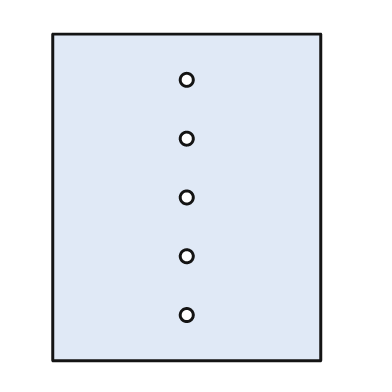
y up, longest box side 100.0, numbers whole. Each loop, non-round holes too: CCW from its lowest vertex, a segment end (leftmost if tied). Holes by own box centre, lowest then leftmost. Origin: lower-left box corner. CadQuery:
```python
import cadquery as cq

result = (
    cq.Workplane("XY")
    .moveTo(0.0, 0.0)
    .lineTo(82.0, 0.0)
    .lineTo(82.0, 100.0)
    .lineTo(0.0, 100.0)
    .close()
    .moveTo(41.0, 14.0)
    .circle(2.0)
    .moveTo(41.0, 32.0)
    .circle(2.0)
    .moveTo(41.0, 50.0)
    .circle(2.0)
    .moveTo(41.0, 68.0)
    .circle(2.0)
    .moveTo(41.0, 86.0)
    .circle(2.0)
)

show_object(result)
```